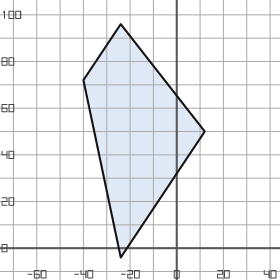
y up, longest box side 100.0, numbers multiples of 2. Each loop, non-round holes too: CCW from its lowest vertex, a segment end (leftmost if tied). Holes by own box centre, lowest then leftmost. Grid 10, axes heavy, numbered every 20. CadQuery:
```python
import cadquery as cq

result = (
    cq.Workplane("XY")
    .moveTo(-24.0, -4.0)
    .lineTo(12.0, 50.0)
    .lineTo(-24.0, 96.0)
    .lineTo(-40.0, 72.0)
    .close()
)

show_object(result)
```